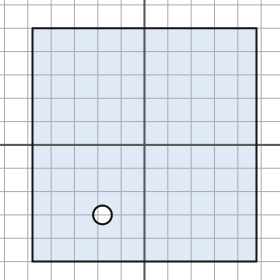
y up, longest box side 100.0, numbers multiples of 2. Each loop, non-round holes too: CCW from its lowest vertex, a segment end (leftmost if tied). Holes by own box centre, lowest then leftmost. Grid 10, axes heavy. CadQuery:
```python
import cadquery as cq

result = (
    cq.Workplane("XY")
    .moveTo(-48.0, -50.0)
    .lineTo(48.0, -50.0)
    .lineTo(48.0, 50.0)
    .lineTo(-48.0, 50.0)
    .close()
    .moveTo(-18.0, -30.0)
    .circle(4.0)
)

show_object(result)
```